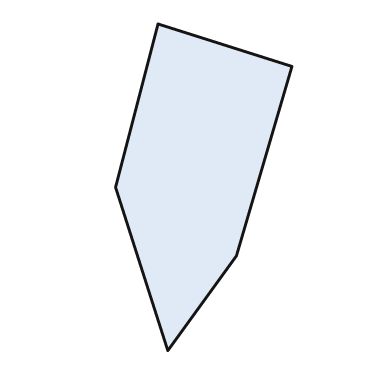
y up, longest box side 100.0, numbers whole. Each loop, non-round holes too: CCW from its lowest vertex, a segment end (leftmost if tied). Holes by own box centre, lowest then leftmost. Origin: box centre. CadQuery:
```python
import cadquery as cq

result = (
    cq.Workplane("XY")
    .moveTo(-11.0, -50.0)
    .lineTo(10.0, -21.0)
    .lineTo(27.0, 37.0)
    .lineTo(-14.0, 50.0)
    .lineTo(-27.0, 0.0)
    .close()
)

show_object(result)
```